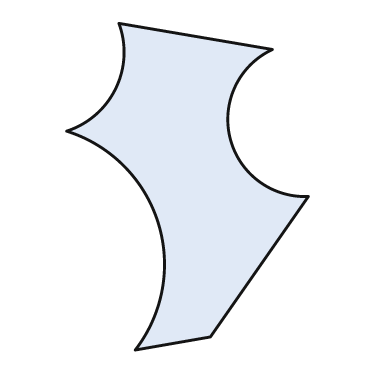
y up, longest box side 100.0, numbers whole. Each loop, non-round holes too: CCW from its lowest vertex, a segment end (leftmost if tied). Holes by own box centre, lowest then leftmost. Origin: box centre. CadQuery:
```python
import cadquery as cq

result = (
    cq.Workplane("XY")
    .moveTo(-16.0, -50.0)
    .lineTo(7.0, -46.0)
    .lineTo(37.0, -3.0)
    .threePointArc((13.0, 15.0), (26.0, 42.0))
    .lineTo(-21.0, 50.0)
    .threePointArc((-22.0, 30.0), (-37.0, 17.0))
    .threePointArc((-9.0, -11.0), (-16.0, -50.0))
    .close()
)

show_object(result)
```